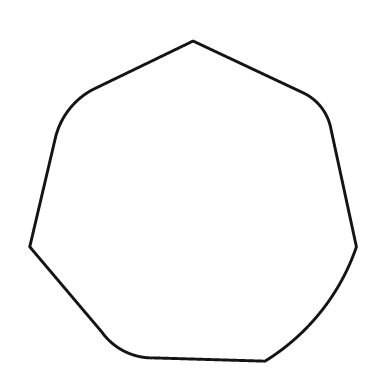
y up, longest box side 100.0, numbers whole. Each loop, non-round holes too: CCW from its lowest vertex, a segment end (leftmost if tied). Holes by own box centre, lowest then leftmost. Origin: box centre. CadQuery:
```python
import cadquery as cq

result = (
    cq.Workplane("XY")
    .moveTo(22.0, -49.0)
    .threePointArc((39.0, -34.0), (50.0, -14.0))
    .lineTo(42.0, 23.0)
    .threePointArc((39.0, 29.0), (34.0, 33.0))
    .lineTo(0.0, 49.0)
    .lineTo(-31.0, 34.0)
    .threePointArc((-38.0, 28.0), (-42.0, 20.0))
    .lineTo(-50.0, -14.0)
    .lineTo(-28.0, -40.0)
    .threePointArc((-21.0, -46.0), (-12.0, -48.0))
    .close()
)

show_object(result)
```